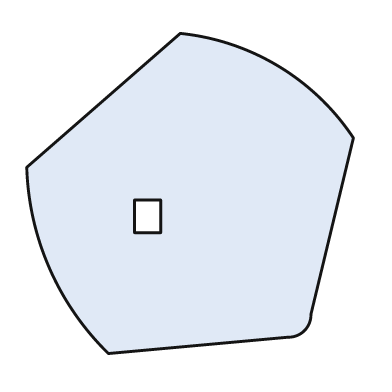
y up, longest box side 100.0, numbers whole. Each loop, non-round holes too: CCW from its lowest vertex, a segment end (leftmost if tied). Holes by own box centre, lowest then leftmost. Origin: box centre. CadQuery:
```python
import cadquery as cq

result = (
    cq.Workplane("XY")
    .moveTo(-25.0, -49.0)
    .lineTo(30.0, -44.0)
    .threePointArc((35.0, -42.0), (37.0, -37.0))
    .lineTo(50.0, 17.0)
    .threePointArc((27.0, 39.0), (-3.0, 49.0))
    .lineTo(-50.0, 8.0)
    .threePointArc((-43.0, -23.0), (-25.0, -49.0))
    .close()
    .moveTo(-17.0, -12.0)
    .lineTo(-9.0, -12.0)
    .lineTo(-9.0, -2.0)
    .lineTo(-17.0, -2.0)
    .close()
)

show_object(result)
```